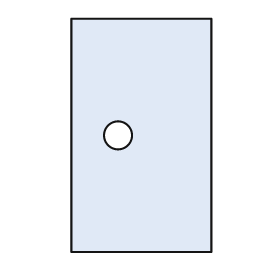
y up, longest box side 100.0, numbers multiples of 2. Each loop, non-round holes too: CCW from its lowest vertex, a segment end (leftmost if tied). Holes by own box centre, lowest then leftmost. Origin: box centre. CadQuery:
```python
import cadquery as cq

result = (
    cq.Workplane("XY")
    .moveTo(-30.0, -50.0)
    .lineTo(30.0, -50.0)
    .lineTo(30.0, 50.0)
    .lineTo(-30.0, 50.0)
    .close()
    .moveTo(-10.0, 0.0)
    .circle(6.0)
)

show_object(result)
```